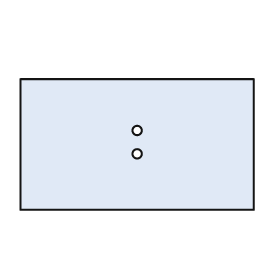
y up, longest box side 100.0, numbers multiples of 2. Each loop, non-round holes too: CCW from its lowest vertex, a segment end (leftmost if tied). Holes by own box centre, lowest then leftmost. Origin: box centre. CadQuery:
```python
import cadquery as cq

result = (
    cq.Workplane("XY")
    .moveTo(-50.0, -28.0)
    .lineTo(50.0, -28.0)
    .lineTo(50.0, 28.0)
    .lineTo(-50.0, 28.0)
    .close()
    .moveTo(0.0, -4.0)
    .circle(2.0)
    .moveTo(0.0, 6.0)
    .circle(2.0)
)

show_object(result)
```